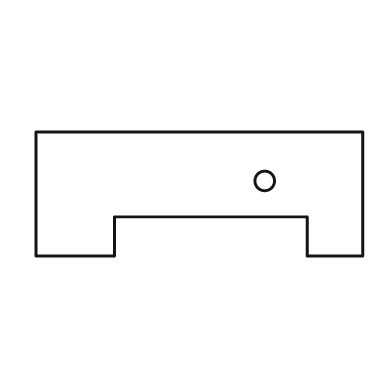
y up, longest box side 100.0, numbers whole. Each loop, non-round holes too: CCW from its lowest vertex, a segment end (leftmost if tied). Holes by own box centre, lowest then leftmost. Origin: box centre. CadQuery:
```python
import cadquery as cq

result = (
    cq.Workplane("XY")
    .moveTo(-50.0, -19.0)
    .lineTo(-26.0, -19.0)
    .lineTo(-26.0, -7.0)
    .lineTo(33.0, -7.0)
    .lineTo(33.0, -19.0)
    .lineTo(50.0, -19.0)
    .lineTo(50.0, 19.0)
    .lineTo(-50.0, 19.0)
    .close()
    .moveTo(20.0, 4.0)
    .circle(3.0)
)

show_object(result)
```